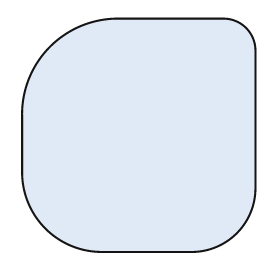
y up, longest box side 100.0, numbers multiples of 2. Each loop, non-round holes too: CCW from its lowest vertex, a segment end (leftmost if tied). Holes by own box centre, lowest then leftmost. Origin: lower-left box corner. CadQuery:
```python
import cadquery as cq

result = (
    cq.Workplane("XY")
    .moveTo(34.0, 0.0)
    .lineTo(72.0, 0.0)
    .threePointArc((92.0, 8.0), (100.0, 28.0))
    .lineTo(100.0, 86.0)
    .threePointArc((96.0, 96.0), (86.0, 100.0))
    .lineTo(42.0, 100.0)
    .threePointArc((12.0, 88.0), (0.0, 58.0))
    .lineTo(0.0, 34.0)
    .threePointArc((10.0, 10.0), (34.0, 0.0))
    .close()
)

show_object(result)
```